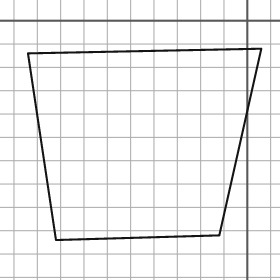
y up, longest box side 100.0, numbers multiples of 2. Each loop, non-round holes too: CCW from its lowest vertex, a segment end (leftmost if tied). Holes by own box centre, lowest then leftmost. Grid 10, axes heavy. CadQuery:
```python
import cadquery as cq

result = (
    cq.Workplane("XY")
    .moveTo(-82.0, -94.0)
    .lineTo(-12.0, -92.0)
    .lineTo(6.0, -12.0)
    .lineTo(-94.0, -14.0)
    .close()
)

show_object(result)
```